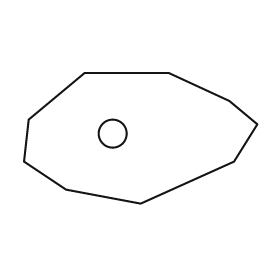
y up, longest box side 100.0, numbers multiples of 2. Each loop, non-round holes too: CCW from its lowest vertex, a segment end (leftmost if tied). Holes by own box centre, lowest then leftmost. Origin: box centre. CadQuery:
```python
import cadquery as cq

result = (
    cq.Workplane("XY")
    .moveTo(0.0, -28.0)
    .lineTo(40.0, -10.0)
    .lineTo(50.0, 6.0)
    .lineTo(38.0, 16.0)
    .lineTo(12.0, 28.0)
    .lineTo(-24.0, 28.0)
    .lineTo(-48.0, 8.0)
    .lineTo(-50.0, -10.0)
    .lineTo(-32.0, -22.0)
    .close()
    .moveTo(-12.0, 2.0)
    .circle(6.0)
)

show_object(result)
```